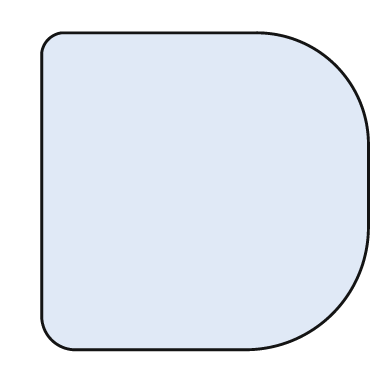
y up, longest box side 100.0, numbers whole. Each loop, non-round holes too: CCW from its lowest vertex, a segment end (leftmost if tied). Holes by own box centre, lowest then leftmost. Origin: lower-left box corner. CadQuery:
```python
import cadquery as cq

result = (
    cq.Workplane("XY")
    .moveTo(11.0, 0.0)
    .lineTo(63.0, 0.0)
    .threePointArc((89.0, 11.0), (100.0, 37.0))
    .lineTo(100.0, 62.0)
    .threePointArc((90.0, 87.0), (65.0, 97.0))
    .lineTo(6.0, 97.0)
    .threePointArc((2.0, 95.0), (0.0, 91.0))
    .lineTo(0.0, 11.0)
    .threePointArc((3.0, 3.0), (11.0, 0.0))
    .close()
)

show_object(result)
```